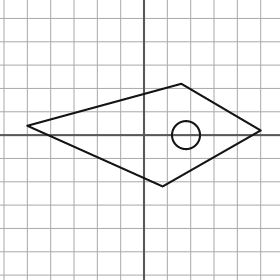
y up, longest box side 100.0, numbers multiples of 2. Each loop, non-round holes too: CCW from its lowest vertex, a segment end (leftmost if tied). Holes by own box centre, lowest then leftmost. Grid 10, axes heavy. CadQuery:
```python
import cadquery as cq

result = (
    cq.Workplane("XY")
    .moveTo(8.0, -22.0)
    .lineTo(50.0, 2.0)
    .lineTo(16.0, 22.0)
    .lineTo(-50.0, 4.0)
    .close()
    .moveTo(18.0, 0.0)
    .circle(6.0)
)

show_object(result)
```